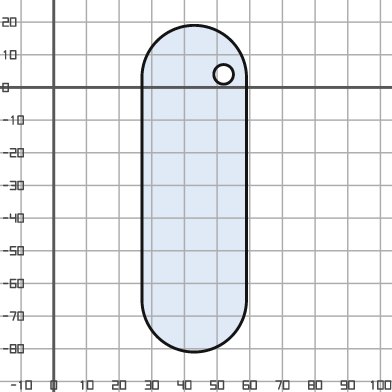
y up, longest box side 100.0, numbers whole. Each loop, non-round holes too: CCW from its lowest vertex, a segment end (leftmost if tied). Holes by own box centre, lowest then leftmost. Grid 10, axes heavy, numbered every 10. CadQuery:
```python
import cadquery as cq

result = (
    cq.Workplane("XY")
    .moveTo(27.0, -65.0)
    .threePointArc((43.0, -81.0), (59.0, -65.0))
    .lineTo(59.0, 3.0)
    .threePointArc((43.0, 19.0), (27.0, 3.0))
    .close()
    .moveTo(52.0, 4.0)
    .circle(3.0)
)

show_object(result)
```